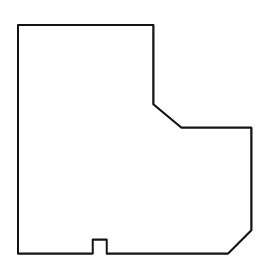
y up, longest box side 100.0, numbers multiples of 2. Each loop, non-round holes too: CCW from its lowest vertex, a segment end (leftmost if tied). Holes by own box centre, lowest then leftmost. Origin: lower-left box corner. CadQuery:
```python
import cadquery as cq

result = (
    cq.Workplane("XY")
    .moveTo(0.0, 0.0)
    .lineTo(32.0, 0.0)
    .lineTo(32.0, 6.0)
    .lineTo(38.0, 6.0)
    .lineTo(38.0, 0.0)
    .lineTo(90.0, 0.0)
    .lineTo(100.0, 10.0)
    .lineTo(100.0, 54.0)
    .lineTo(70.0, 54.0)
    .lineTo(58.0, 64.0)
    .lineTo(58.0, 98.0)
    .lineTo(0.0, 98.0)
    .close()
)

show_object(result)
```